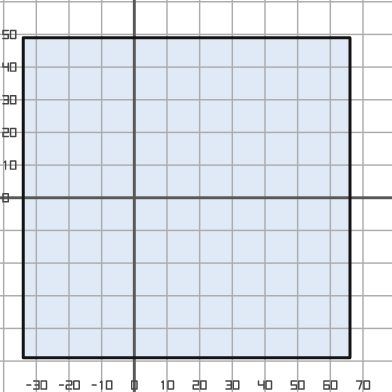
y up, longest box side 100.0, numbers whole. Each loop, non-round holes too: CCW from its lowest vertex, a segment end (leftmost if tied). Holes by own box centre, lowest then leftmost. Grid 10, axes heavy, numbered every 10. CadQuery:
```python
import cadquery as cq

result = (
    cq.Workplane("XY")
    .moveTo(-34.0, -49.0)
    .lineTo(66.0, -49.0)
    .lineTo(66.0, 49.0)
    .lineTo(-34.0, 49.0)
    .close()
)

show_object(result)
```